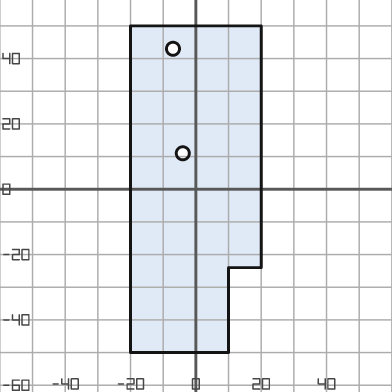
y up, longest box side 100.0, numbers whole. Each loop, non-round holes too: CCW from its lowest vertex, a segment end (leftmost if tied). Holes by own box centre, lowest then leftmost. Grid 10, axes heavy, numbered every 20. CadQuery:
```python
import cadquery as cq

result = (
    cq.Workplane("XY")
    .moveTo(-20.0, -50.0)
    .lineTo(10.0, -50.0)
    .lineTo(10.0, -24.0)
    .lineTo(20.0, -24.0)
    .lineTo(20.0, 50.0)
    .lineTo(-20.0, 50.0)
    .close()
    .moveTo(-4.0, 11.0)
    .circle(2.0)
    .moveTo(-7.0, 43.0)
    .circle(2.0)
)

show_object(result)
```